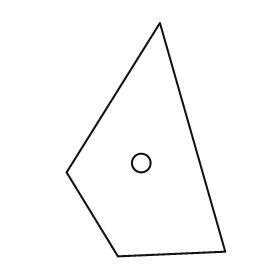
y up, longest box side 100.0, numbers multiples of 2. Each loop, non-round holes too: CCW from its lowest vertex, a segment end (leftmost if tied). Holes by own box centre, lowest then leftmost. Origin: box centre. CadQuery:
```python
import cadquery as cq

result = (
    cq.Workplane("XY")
    .moveTo(-12.0, -50.0)
    .lineTo(34.0, -48.0)
    .lineTo(6.0, 50.0)
    .lineTo(-34.0, -14.0)
    .close()
    .moveTo(-2.0, -10.0)
    .circle(4.0)
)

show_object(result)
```